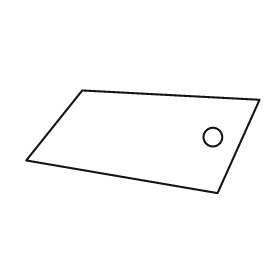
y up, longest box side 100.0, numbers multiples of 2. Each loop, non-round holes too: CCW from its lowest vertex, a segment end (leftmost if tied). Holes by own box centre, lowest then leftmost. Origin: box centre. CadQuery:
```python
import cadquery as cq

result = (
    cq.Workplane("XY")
    .moveTo(32.0, -22.0)
    .lineTo(50.0, 18.0)
    .lineTo(-26.0, 22.0)
    .lineTo(-50.0, -8.0)
    .close()
    .moveTo(30.0, 2.0)
    .circle(4.0)
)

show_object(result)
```